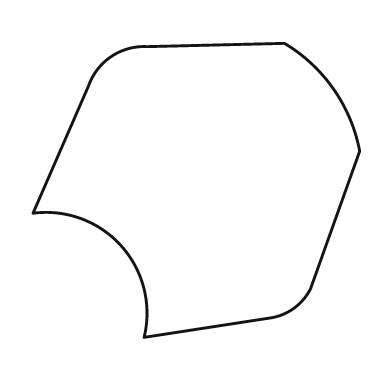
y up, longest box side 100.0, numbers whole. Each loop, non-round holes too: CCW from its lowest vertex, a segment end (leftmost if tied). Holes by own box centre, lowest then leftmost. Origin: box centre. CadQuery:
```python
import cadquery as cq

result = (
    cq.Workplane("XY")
    .moveTo(-16.0, -45.0)
    .lineTo(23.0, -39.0)
    .threePointArc((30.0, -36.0), (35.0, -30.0))
    .lineTo(50.0, 12.0)
    .threePointArc((42.0, 31.0), (27.0, 45.0))
    .lineTo(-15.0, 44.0)
    .threePointArc((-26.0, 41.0), (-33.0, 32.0))
    .lineTo(-50.0, -7.0)
    .threePointArc((-23.0, -17.0), (-16.0, -45.0))
    .close()
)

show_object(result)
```